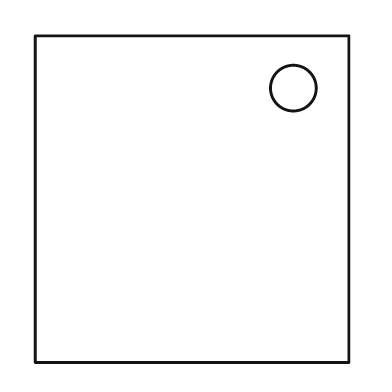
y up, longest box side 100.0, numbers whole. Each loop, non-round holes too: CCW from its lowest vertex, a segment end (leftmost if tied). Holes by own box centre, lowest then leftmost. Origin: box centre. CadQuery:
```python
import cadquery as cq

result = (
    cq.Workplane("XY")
    .moveTo(-48.0, -50.0)
    .lineTo(48.0, -50.0)
    .lineTo(48.0, 50.0)
    .lineTo(-48.0, 50.0)
    .close()
    .moveTo(31.0, 34.0)
    .circle(7.0)
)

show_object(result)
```